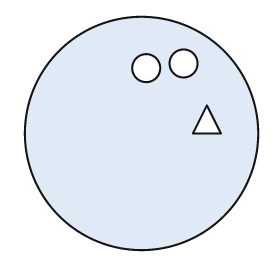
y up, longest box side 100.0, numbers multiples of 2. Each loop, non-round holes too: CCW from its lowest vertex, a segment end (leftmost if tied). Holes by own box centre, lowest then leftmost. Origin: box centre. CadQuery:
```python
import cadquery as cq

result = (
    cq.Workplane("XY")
    .moveTo(0.0, 0.0)
    .circle(50.0)
    .moveTo(22.0, 0.0)
    .lineTo(34.0, 0.0)
    .lineTo(28.0, 12.0)
    .close()
    .moveTo(2.0, 28.0)
    .circle(6.0)
    .moveTo(18.0, 30.0)
    .circle(6.0)
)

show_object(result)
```